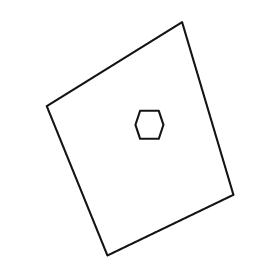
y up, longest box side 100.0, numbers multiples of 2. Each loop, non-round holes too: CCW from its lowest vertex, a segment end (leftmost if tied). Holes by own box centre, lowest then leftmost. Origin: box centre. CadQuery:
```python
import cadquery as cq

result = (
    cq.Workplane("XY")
    .moveTo(-14.0, -50.0)
    .lineTo(40.0, -24.0)
    .lineTo(18.0, 50.0)
    .lineTo(-40.0, 14.0)
    .close()
    .moveTo(0.0, 0.0)
    .lineTo(8.0, 0.0)
    .lineTo(10.0, 6.0)
    .lineTo(8.0, 12.0)
    .lineTo(0.0, 12.0)
    .lineTo(-2.0, 6.0)
    .close()
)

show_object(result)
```